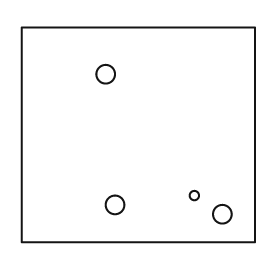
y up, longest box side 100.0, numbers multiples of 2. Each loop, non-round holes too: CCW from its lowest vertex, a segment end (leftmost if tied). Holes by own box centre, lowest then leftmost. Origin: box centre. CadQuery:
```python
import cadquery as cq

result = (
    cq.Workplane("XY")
    .moveTo(-50.0, -46.0)
    .lineTo(50.0, -46.0)
    .lineTo(50.0, 46.0)
    .lineTo(-50.0, 46.0)
    .close()
    .moveTo(36.0, -34.0)
    .circle(4.0)
    .moveTo(-10.0, -30.0)
    .circle(4.0)
    .moveTo(24.0, -26.0)
    .circle(2.0)
    .moveTo(-14.0, 26.0)
    .circle(4.0)
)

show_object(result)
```